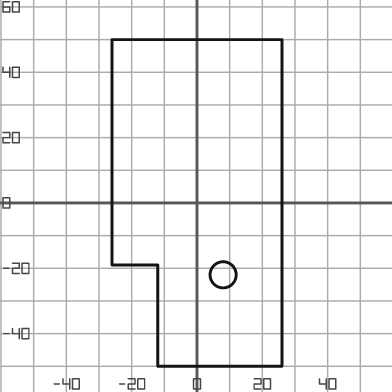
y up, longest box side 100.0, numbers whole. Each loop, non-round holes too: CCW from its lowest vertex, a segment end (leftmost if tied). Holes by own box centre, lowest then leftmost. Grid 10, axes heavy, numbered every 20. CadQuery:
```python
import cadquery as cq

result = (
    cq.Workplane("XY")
    .moveTo(-12.0, -50.0)
    .lineTo(26.0, -50.0)
    .lineTo(26.0, 50.0)
    .lineTo(-26.0, 50.0)
    .lineTo(-26.0, -19.0)
    .lineTo(-12.0, -19.0)
    .close()
    .moveTo(8.0, -22.0)
    .circle(4.0)
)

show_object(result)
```